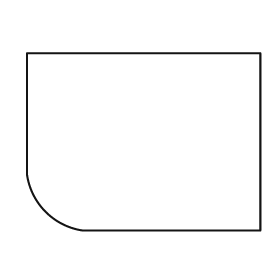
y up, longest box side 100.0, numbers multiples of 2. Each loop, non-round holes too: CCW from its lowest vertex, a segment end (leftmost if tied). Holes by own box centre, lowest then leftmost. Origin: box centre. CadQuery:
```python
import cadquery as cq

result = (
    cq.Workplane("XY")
    .moveTo(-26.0, -38.0)
    .lineTo(50.0, -38.0)
    .lineTo(50.0, 38.0)
    .lineTo(-50.0, 38.0)
    .lineTo(-50.0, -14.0)
    .threePointArc((-42.0, -30.0), (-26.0, -38.0))
    .close()
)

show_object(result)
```